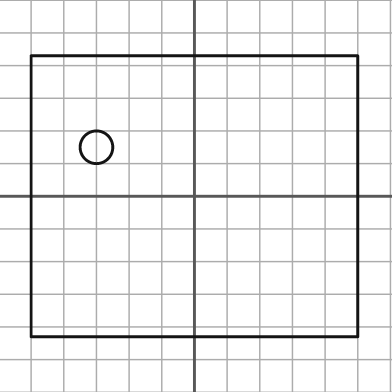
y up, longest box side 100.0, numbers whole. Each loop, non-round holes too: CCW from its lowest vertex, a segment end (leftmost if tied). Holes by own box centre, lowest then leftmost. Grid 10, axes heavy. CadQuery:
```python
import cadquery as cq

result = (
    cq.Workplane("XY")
    .moveTo(-50.0, -43.0)
    .lineTo(50.0, -43.0)
    .lineTo(50.0, 43.0)
    .lineTo(-50.0, 43.0)
    .close()
    .moveTo(-30.0, 15.0)
    .circle(5.0)
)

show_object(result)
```